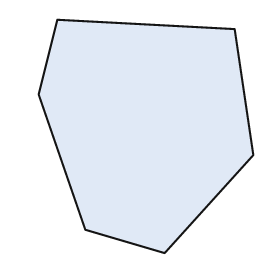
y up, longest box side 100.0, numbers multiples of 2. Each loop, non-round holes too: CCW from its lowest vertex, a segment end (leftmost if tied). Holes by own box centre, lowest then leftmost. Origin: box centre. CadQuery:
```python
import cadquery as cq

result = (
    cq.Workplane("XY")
    .moveTo(8.0, -50.0)
    .lineTo(46.0, -8.0)
    .lineTo(38.0, 46.0)
    .lineTo(-38.0, 50.0)
    .lineTo(-46.0, 18.0)
    .lineTo(-26.0, -40.0)
    .close()
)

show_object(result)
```